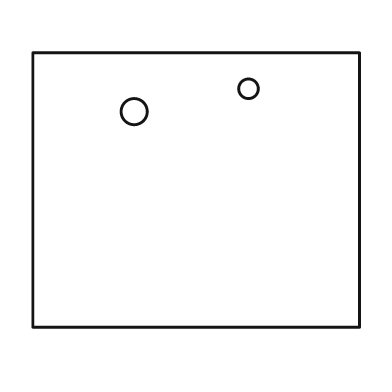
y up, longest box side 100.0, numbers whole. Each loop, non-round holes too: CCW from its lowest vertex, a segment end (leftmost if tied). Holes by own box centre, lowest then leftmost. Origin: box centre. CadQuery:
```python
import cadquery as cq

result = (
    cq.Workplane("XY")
    .moveTo(-50.0, -42.0)
    .lineTo(50.0, -42.0)
    .lineTo(50.0, 42.0)
    .lineTo(-50.0, 42.0)
    .close()
    .moveTo(-19.0, 24.0)
    .circle(4.0)
    .moveTo(16.0, 31.0)
    .circle(3.0)
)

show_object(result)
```